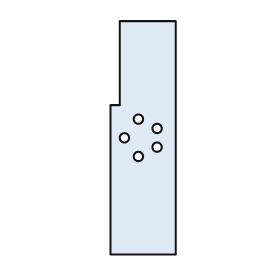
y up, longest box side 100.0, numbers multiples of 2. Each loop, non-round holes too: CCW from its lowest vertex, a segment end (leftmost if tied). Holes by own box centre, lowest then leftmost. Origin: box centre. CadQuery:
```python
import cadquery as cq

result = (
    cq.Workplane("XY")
    .moveTo(-14.0, -50.0)
    .lineTo(14.0, -50.0)
    .lineTo(14.0, 50.0)
    .lineTo(-10.0, 50.0)
    .lineTo(-10.0, 14.0)
    .lineTo(-14.0, 14.0)
    .close()
    .moveTo(-2.0, -8.0)
    .circle(2.0)
    .moveTo(6.0, -4.0)
    .circle(2.0)
    .moveTo(-8.0, 0.0)
    .circle(2.0)
    .moveTo(6.0, 4.0)
    .circle(2.0)
    .moveTo(-2.0, 8.0)
    .circle(2.0)
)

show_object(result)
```